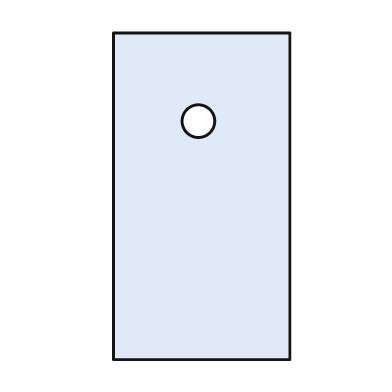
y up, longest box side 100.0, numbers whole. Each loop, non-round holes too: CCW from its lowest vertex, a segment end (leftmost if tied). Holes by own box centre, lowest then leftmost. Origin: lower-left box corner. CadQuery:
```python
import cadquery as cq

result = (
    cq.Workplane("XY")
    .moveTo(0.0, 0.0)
    .lineTo(54.0, 0.0)
    .lineTo(54.0, 100.0)
    .lineTo(0.0, 100.0)
    .close()
    .moveTo(26.0, 73.0)
    .circle(5.0)
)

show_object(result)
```